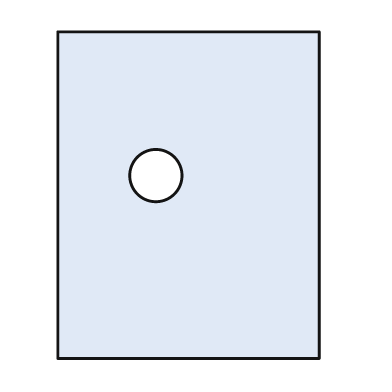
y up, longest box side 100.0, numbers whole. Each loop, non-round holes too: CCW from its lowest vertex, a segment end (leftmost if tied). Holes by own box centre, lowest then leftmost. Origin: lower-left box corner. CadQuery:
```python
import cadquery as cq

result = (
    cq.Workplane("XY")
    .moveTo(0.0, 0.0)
    .lineTo(80.0, 0.0)
    .lineTo(80.0, 100.0)
    .lineTo(0.0, 100.0)
    .close()
    .moveTo(30.0, 56.0)
    .circle(8.0)
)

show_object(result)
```